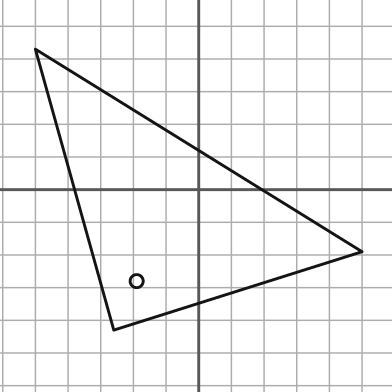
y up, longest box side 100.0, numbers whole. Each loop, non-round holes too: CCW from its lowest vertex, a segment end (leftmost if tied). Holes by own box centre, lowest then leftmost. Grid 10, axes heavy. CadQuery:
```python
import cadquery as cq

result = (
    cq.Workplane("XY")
    .moveTo(-26.0, -43.0)
    .lineTo(50.0, -19.0)
    .lineTo(-50.0, 43.0)
    .close()
    .moveTo(-19.0, -28.0)
    .circle(2.0)
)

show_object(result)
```